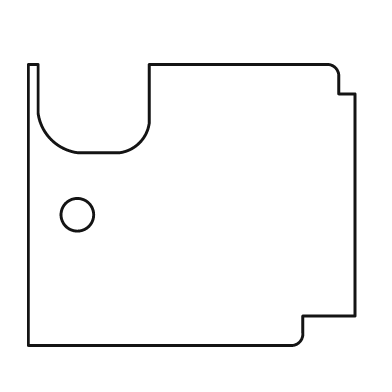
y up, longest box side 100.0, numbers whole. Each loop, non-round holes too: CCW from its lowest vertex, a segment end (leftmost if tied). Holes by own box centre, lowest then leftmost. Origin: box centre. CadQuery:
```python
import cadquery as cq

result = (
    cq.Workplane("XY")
    .moveTo(-50.0, -43.0)
    .lineTo(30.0, -43.0)
    .threePointArc((33.0, -42.0), (34.0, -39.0))
    .lineTo(34.0, -34.0)
    .lineTo(50.0, -34.0)
    .lineTo(50.0, 34.0)
    .lineTo(45.0, 34.0)
    .lineTo(45.0, 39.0)
    .threePointArc((44.0, 42.0), (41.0, 43.0))
    .lineTo(-13.0, 43.0)
    .lineTo(-13.0, 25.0)
    .threePointArc((-16.0, 19.0), (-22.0, 16.0))
    .lineTo(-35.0, 16.0)
    .threePointArc((-43.0, 20.0), (-47.0, 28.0))
    .lineTo(-47.0, 43.0)
    .lineTo(-50.0, 43.0)
    .close()
    .moveTo(-35.0, -3.0)
    .circle(5.0)
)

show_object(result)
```